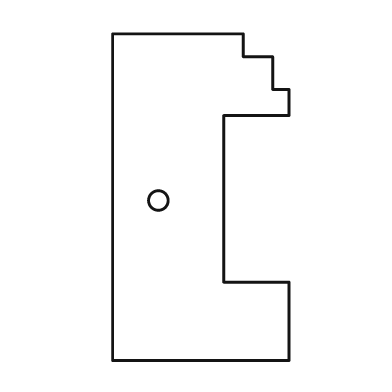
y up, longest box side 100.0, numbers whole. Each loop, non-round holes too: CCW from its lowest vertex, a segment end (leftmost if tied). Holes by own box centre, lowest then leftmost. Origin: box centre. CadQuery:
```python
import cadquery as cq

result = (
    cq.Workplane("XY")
    .moveTo(-27.0, -50.0)
    .lineTo(27.0, -50.0)
    .lineTo(27.0, -26.0)
    .lineTo(7.0, -26.0)
    .lineTo(7.0, 25.0)
    .lineTo(27.0, 25.0)
    .lineTo(27.0, 33.0)
    .lineTo(22.0, 33.0)
    .lineTo(22.0, 43.0)
    .lineTo(13.0, 43.0)
    .lineTo(13.0, 50.0)
    .lineTo(-27.0, 50.0)
    .close()
    .moveTo(-13.0, -1.0)
    .circle(3.0)
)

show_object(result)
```